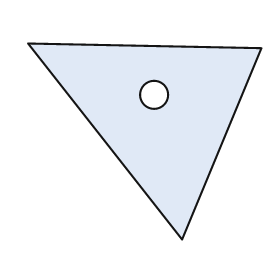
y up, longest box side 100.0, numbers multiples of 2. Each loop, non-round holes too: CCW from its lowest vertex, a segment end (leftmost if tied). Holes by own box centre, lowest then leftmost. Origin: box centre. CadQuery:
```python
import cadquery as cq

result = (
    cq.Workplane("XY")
    .moveTo(16.0, -42.0)
    .lineTo(50.0, 40.0)
    .lineTo(-50.0, 42.0)
    .close()
    .moveTo(4.0, 20.0)
    .circle(6.0)
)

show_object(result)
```